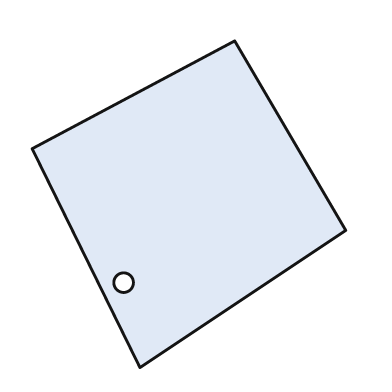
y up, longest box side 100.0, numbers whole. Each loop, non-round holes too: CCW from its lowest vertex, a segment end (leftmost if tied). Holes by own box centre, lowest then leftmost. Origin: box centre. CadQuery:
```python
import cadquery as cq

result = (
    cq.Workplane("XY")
    .moveTo(-15.0, -50.0)
    .lineTo(48.0, -8.0)
    .lineTo(14.0, 50.0)
    .lineTo(-48.0, 17.0)
    .close()
    .moveTo(-20.0, -24.0)
    .circle(3.0)
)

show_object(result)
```